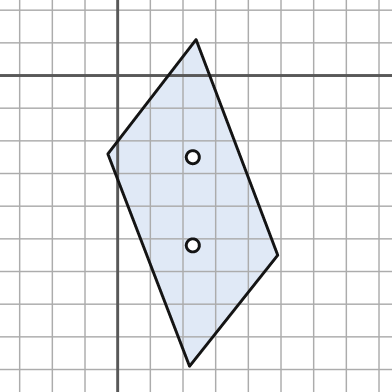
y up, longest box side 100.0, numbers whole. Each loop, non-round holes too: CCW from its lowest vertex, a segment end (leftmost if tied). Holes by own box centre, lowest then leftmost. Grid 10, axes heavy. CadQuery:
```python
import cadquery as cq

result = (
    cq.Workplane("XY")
    .moveTo(22.0, -89.0)
    .lineTo(49.0, -55.0)
    .lineTo(24.0, 11.0)
    .lineTo(-3.0, -24.0)
    .close()
    .moveTo(23.0, -52.0)
    .circle(2.0)
    .moveTo(23.0, -25.0)
    .circle(2.0)
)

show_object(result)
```